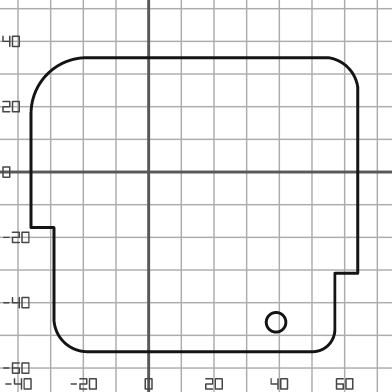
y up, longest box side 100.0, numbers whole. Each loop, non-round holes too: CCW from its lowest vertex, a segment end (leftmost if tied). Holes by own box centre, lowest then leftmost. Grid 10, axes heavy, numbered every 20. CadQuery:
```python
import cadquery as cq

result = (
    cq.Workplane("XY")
    .moveTo(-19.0, -55.0)
    .lineTo(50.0, -55.0)
    .threePointArc((55.0, -53.0), (57.0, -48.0))
    .lineTo(57.0, -31.0)
    .lineTo(64.0, -31.0)
    .lineTo(64.0, 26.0)
    .threePointArc((61.0, 32.0), (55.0, 35.0))
    .lineTo(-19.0, 35.0)
    .threePointArc((-31.0, 30.0), (-36.0, 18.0))
    .lineTo(-36.0, -17.0)
    .lineTo(-29.0, -17.0)
    .lineTo(-29.0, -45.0)
    .threePointArc((-26.0, -52.0), (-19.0, -55.0))
    .close()
    .moveTo(39.0, -46.0)
    .circle(3.0)
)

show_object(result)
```